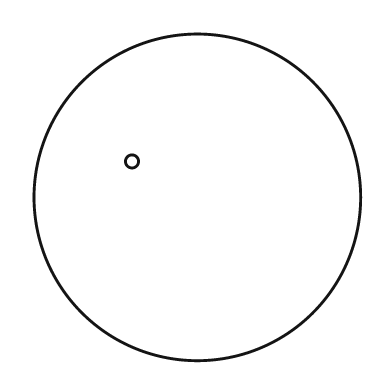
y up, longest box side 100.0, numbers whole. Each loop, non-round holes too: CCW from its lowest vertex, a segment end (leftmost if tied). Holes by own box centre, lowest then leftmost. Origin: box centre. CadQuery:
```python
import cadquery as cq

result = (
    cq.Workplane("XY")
    .moveTo(0.0, 0.0)
    .circle(50.0)
    .moveTo(-20.0, 11.0)
    .circle(2.0)
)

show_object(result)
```